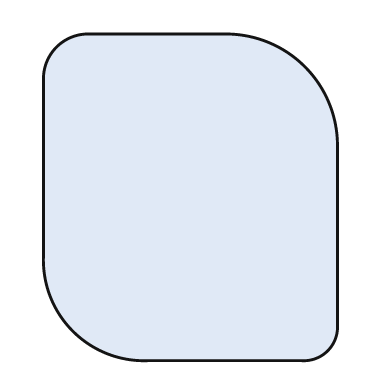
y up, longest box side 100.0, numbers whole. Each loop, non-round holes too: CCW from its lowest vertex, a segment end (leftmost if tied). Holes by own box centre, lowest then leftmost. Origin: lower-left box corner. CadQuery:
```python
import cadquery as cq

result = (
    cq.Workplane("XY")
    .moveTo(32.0, 0.0)
    .lineTo(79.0, 0.0)
    .threePointArc((87.0, 3.0), (90.0, 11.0))
    .lineTo(90.0, 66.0)
    .threePointArc((80.0, 90.0), (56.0, 100.0))
    .lineTo(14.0, 100.0)
    .threePointArc((4.0, 96.0), (0.0, 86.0))
    .lineTo(0.0, 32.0)
    .threePointArc((9.0, 9.0), (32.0, 0.0))
    .close()
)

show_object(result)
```